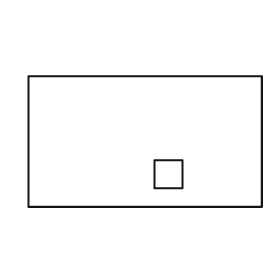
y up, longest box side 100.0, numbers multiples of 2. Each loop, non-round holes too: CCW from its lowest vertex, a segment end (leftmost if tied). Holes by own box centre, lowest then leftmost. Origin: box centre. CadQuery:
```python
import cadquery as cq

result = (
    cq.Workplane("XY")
    .moveTo(-50.0, -28.0)
    .lineTo(50.0, -28.0)
    .lineTo(50.0, 28.0)
    .lineTo(-50.0, 28.0)
    .close()
    .moveTo(4.0, -20.0)
    .lineTo(16.0, -20.0)
    .lineTo(16.0, -8.0)
    .lineTo(4.0, -8.0)
    .close()
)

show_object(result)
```